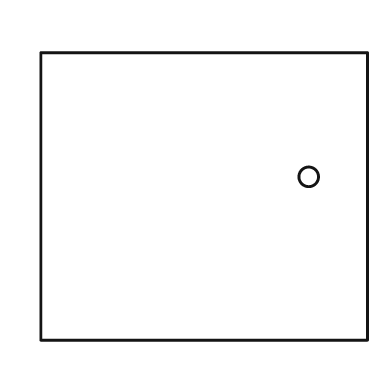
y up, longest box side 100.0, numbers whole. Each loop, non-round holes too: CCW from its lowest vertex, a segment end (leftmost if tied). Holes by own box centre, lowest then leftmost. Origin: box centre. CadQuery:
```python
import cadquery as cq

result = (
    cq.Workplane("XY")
    .moveTo(-50.0, -44.0)
    .lineTo(50.0, -44.0)
    .lineTo(50.0, 44.0)
    .lineTo(-50.0, 44.0)
    .close()
    .moveTo(32.0, 6.0)
    .circle(3.0)
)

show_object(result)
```